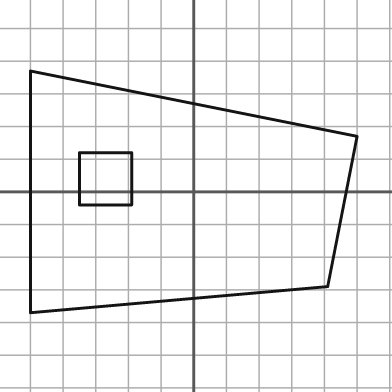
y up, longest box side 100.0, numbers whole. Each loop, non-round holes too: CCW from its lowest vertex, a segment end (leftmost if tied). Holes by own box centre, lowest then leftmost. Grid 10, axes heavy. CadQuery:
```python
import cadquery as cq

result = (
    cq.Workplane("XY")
    .moveTo(-50.0, -37.0)
    .lineTo(41.0, -29.0)
    .lineTo(50.0, 17.0)
    .lineTo(-50.0, 37.0)
    .close()
    .moveTo(-35.0, -4.0)
    .lineTo(-19.0, -4.0)
    .lineTo(-19.0, 12.0)
    .lineTo(-35.0, 12.0)
    .close()
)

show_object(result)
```